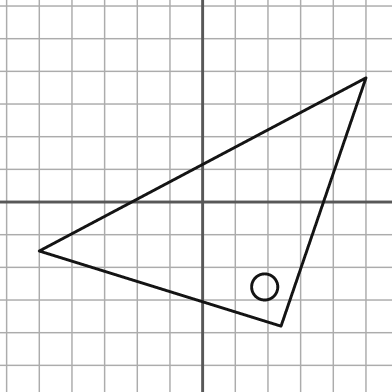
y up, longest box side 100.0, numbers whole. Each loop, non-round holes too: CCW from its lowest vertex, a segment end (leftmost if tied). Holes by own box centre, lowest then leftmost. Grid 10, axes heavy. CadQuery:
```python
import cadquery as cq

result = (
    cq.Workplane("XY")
    .moveTo(24.0, -38.0)
    .lineTo(50.0, 38.0)
    .lineTo(-50.0, -15.0)
    .close()
    .moveTo(19.0, -26.0)
    .circle(4.0)
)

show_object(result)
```